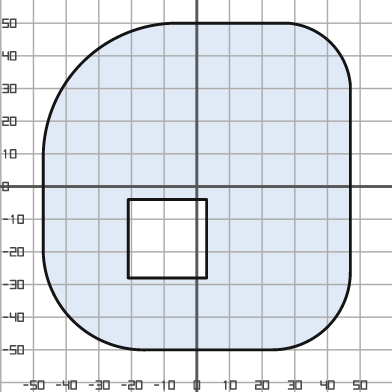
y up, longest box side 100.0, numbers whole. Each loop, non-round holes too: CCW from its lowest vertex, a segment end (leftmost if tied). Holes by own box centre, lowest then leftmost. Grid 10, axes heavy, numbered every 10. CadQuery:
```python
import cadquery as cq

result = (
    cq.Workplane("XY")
    .moveTo(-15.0, -50.0)
    .lineTo(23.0, -50.0)
    .threePointArc((40.0, -43.0), (47.0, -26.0))
    .lineTo(47.0, 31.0)
    .threePointArc((41.0, 44.0), (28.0, 50.0))
    .lineTo(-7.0, 50.0)
    .threePointArc((-35.0, 38.0), (-47.0, 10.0))
    .lineTo(-47.0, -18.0)
    .threePointArc((-38.0, -41.0), (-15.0, -50.0))
    .close()
    .moveTo(-21.0, -28.0)
    .lineTo(3.0, -28.0)
    .lineTo(3.0, -4.0)
    .lineTo(-21.0, -4.0)
    .close()
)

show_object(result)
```